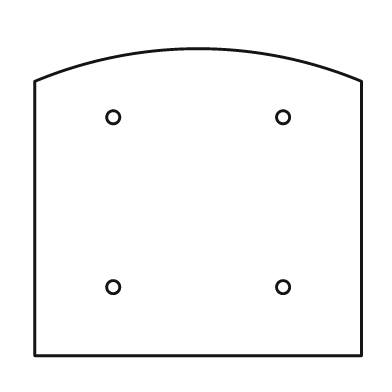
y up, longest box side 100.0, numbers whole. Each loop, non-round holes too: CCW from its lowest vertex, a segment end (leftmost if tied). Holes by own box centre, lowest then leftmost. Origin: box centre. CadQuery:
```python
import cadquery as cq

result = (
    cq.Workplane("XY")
    .moveTo(-50.0, -47.0)
    .lineTo(50.0, -47.0)
    .lineTo(50.0, 37.0)
    .threePointArc((0.0, 47.0), (-50.0, 37.0))
    .close()
    .moveTo(-26.0, -26.0)
    .circle(2.0)
    .moveTo(26.0, -26.0)
    .circle(2.0)
    .moveTo(-26.0, 26.0)
    .circle(2.0)
    .moveTo(26.0, 26.0)
    .circle(2.0)
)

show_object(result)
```